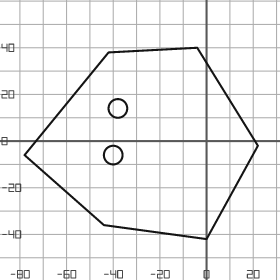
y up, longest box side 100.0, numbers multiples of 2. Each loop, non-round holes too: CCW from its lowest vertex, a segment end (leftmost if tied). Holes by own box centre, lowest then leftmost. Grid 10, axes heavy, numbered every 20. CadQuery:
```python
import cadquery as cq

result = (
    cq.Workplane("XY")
    .moveTo(0.0, -42.0)
    .lineTo(22.0, -2.0)
    .lineTo(-4.0, 40.0)
    .lineTo(-42.0, 38.0)
    .lineTo(-78.0, -6.0)
    .lineTo(-44.0, -36.0)
    .close()
    .moveTo(-40.0, -6.0)
    .circle(4.0)
    .moveTo(-38.0, 14.0)
    .circle(4.0)
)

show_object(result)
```